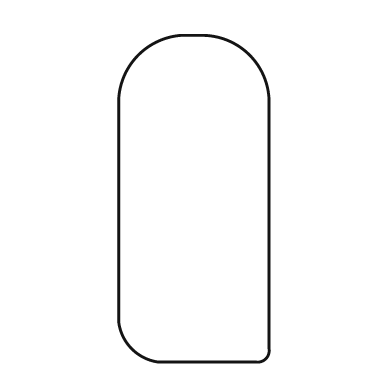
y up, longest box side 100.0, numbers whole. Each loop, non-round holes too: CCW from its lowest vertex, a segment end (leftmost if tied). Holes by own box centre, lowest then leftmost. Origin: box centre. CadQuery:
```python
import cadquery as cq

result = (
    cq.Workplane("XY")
    .moveTo(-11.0, -50.0)
    .lineTo(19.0, -50.0)
    .threePointArc((22.0, -49.0), (23.0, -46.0))
    .lineTo(23.0, 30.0)
    .threePointArc((17.0, 44.0), (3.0, 50.0))
    .lineTo(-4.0, 50.0)
    .threePointArc((-17.0, 44.0), (-23.0, 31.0))
    .lineTo(-23.0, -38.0)
    .threePointArc((-19.0, -46.0), (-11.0, -50.0))
    .close()
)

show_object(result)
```